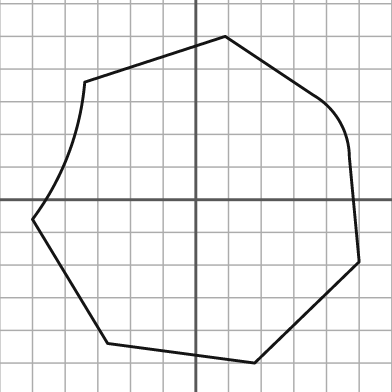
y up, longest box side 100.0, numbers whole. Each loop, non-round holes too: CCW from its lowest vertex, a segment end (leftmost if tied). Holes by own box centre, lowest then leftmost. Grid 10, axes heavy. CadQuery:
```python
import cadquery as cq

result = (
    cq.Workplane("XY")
    .moveTo(18.0, -50.0)
    .lineTo(50.0, -19.0)
    .lineTo(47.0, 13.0)
    .threePointArc((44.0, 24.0), (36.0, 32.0))
    .lineTo(9.0, 50.0)
    .lineTo(-34.0, 36.0)
    .threePointArc((-39.0, 14.0), (-50.0, -6.0))
    .lineTo(-27.0, -44.0)
    .close()
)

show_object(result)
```